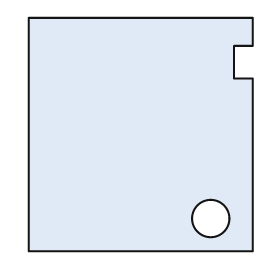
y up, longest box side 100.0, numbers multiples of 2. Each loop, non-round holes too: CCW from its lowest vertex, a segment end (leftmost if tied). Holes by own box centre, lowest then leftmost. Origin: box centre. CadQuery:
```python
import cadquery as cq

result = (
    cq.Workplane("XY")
    .moveTo(-48.0, -50.0)
    .lineTo(48.0, -50.0)
    .lineTo(48.0, 24.0)
    .lineTo(40.0, 24.0)
    .lineTo(40.0, 38.0)
    .lineTo(48.0, 38.0)
    .lineTo(48.0, 50.0)
    .lineTo(-48.0, 50.0)
    .close()
    .moveTo(30.0, -36.0)
    .circle(8.0)
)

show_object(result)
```